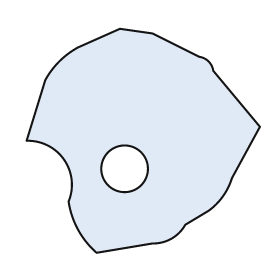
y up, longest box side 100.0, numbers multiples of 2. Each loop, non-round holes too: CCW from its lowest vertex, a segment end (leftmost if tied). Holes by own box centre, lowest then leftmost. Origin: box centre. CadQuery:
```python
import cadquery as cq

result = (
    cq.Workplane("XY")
    .moveTo(-20.0, -48.0)
    .lineTo(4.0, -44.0)
    .threePointArc((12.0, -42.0), (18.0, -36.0))
    .lineTo(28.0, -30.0)
    .threePointArc((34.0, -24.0), (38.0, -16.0))
    .lineTo(50.0, 6.0)
    .lineTo(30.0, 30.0)
    .threePointArc((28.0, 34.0), (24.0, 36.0))
    .lineTo(4.0, 46.0)
    .lineTo(-10.0, 48.0)
    .lineTo(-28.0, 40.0)
    .threePointArc((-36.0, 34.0), (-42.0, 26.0))
    .lineTo(-50.0, 0.0)
    .threePointArc((-34.0, -8.0), (-32.0, -26.0))
    .threePointArc((-28.0, -38.0), (-20.0, -48.0))
    .close()
    .moveTo(-8.0, -12.0)
    .circle(10.0)
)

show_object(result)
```